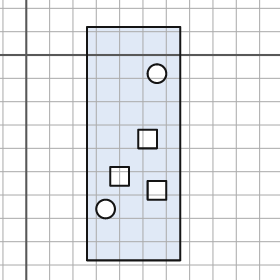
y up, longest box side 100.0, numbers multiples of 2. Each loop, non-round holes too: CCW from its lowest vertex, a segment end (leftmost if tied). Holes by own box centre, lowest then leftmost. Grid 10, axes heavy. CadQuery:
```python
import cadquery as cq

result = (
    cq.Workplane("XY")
    .moveTo(26.0, -88.0)
    .lineTo(66.0, -88.0)
    .lineTo(66.0, 12.0)
    .lineTo(26.0, 12.0)
    .close()
    .moveTo(34.0, -66.0)
    .circle(4.0)
    .moveTo(52.0, -62.0)
    .lineTo(60.0, -62.0)
    .lineTo(60.0, -54.0)
    .lineTo(52.0, -54.0)
    .close()
    .moveTo(36.0, -56.0)
    .lineTo(44.0, -56.0)
    .lineTo(44.0, -48.0)
    .lineTo(36.0, -48.0)
    .close()
    .moveTo(48.0, -40.0)
    .lineTo(56.0, -40.0)
    .lineTo(56.0, -32.0)
    .lineTo(48.0, -32.0)
    .close()
    .moveTo(56.0, -8.0)
    .circle(4.0)
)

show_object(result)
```